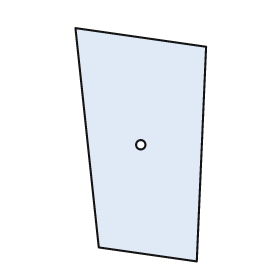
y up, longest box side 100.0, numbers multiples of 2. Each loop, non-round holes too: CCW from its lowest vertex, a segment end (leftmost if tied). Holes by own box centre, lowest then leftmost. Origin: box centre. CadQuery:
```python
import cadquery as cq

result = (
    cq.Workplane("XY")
    .moveTo(24.0, -50.0)
    .lineTo(28.0, 42.0)
    .lineTo(-28.0, 50.0)
    .lineTo(-18.0, -44.0)
    .close()
    .moveTo(0.0, 0.0)
    .circle(2.0)
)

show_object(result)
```